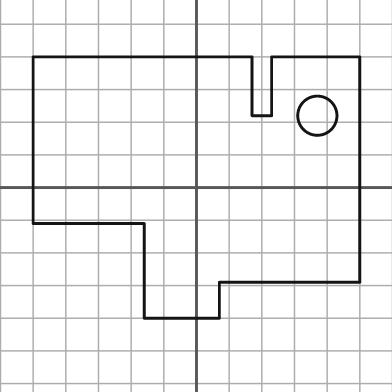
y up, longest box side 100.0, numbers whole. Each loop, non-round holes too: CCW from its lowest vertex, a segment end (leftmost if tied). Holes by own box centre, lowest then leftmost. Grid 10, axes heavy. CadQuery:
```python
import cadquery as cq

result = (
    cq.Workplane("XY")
    .moveTo(-16.0, -40.0)
    .lineTo(7.0, -40.0)
    .lineTo(7.0, -29.0)
    .lineTo(50.0, -29.0)
    .lineTo(50.0, 40.0)
    .lineTo(23.0, 40.0)
    .lineTo(23.0, 22.0)
    .lineTo(17.0, 22.0)
    .lineTo(17.0, 40.0)
    .lineTo(-50.0, 40.0)
    .lineTo(-50.0, -11.0)
    .lineTo(-16.0, -11.0)
    .close()
    .moveTo(37.0, 22.0)
    .circle(6.0)
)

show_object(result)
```